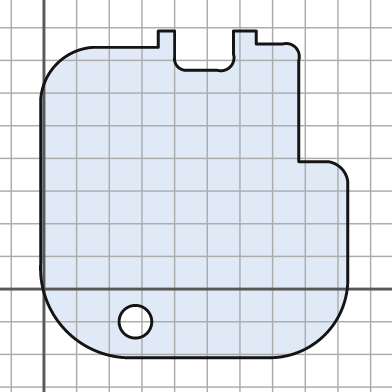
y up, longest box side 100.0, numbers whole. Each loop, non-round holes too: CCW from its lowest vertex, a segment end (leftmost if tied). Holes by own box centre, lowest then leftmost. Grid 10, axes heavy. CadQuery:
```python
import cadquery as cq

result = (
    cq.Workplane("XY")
    .moveTo(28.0, -21.0)
    .lineTo(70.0, -21.0)
    .threePointArc((86.0, -14.0), (93.0, 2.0))
    .lineTo(93.0, 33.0)
    .threePointArc((91.0, 37.0), (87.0, 39.0))
    .lineTo(78.0, 39.0)
    .lineTo(78.0, 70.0)
    .threePointArc((77.0, 74.0), (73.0, 75.0))
    .lineTo(65.0, 75.0)
    .lineTo(65.0, 79.0)
    .lineTo(58.0, 79.0)
    .lineTo(58.0, 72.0)
    .threePointArc((57.0, 68.0), (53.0, 67.0))
    .lineTo(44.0, 67.0)
    .threePointArc((41.0, 68.0), (40.0, 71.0))
    .lineTo(40.0, 79.0)
    .lineTo(35.0, 79.0)
    .lineTo(35.0, 74.0)
    .lineTo(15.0, 74.0)
    .threePointArc((4.0, 69.0), (-1.0, 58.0))
    .lineTo(-1.0, 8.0)
    .threePointArc((7.0, -13.0), (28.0, -21.0))
    .close()
    .moveTo(28.0, -10.0)
    .circle(5.0)
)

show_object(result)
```